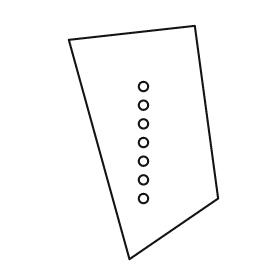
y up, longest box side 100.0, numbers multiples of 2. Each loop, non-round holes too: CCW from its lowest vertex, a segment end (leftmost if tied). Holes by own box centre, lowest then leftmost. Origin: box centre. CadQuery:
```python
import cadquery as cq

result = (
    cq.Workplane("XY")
    .moveTo(-6.0, -50.0)
    .lineTo(32.0, -24.0)
    .lineTo(22.0, 50.0)
    .lineTo(-32.0, 44.0)
    .close()
    .moveTo(0.0, -24.0)
    .circle(2.0)
    .moveTo(0.0, -16.0)
    .circle(2.0)
    .moveTo(0.0, -8.0)
    .circle(2.0)
    .moveTo(0.0, 0.0)
    .circle(2.0)
    .moveTo(0.0, 8.0)
    .circle(2.0)
    .moveTo(0.0, 16.0)
    .circle(2.0)
    .moveTo(0.0, 24.0)
    .circle(2.0)
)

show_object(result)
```